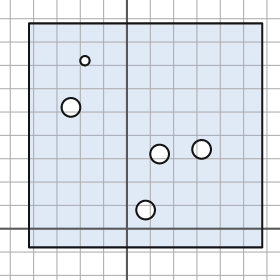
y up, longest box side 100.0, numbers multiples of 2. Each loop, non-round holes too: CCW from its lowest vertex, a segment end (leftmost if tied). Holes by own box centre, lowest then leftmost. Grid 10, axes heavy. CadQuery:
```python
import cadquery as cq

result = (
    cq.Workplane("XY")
    .moveTo(-42.0, -8.0)
    .lineTo(58.0, -8.0)
    .lineTo(58.0, 88.0)
    .lineTo(-42.0, 88.0)
    .close()
    .moveTo(8.0, 8.0)
    .circle(4.0)
    .moveTo(14.0, 32.0)
    .circle(4.0)
    .moveTo(32.0, 34.0)
    .circle(4.0)
    .moveTo(-24.0, 52.0)
    .circle(4.0)
    .moveTo(-18.0, 72.0)
    .circle(2.0)
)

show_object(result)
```